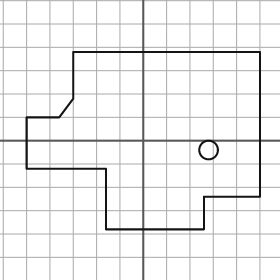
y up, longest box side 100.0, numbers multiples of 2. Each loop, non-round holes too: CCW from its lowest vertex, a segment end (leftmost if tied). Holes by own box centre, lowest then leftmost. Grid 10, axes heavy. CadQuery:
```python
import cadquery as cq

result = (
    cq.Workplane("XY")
    .moveTo(-16.0, -38.0)
    .lineTo(26.0, -38.0)
    .lineTo(26.0, -24.0)
    .lineTo(50.0, -24.0)
    .lineTo(50.0, 38.0)
    .lineTo(-30.0, 38.0)
    .lineTo(-30.0, 18.0)
    .lineTo(-36.0, 10.0)
    .lineTo(-50.0, 10.0)
    .lineTo(-50.0, -12.0)
    .lineTo(-16.0, -12.0)
    .close()
    .moveTo(28.0, -4.0)
    .circle(4.0)
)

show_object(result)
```